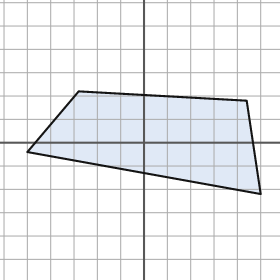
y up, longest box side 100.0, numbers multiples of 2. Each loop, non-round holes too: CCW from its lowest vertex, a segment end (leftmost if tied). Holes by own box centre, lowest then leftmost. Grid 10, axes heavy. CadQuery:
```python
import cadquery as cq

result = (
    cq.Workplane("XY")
    .moveTo(50.0, -22.0)
    .lineTo(44.0, 18.0)
    .lineTo(-28.0, 22.0)
    .lineTo(-50.0, -4.0)
    .close()
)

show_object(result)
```